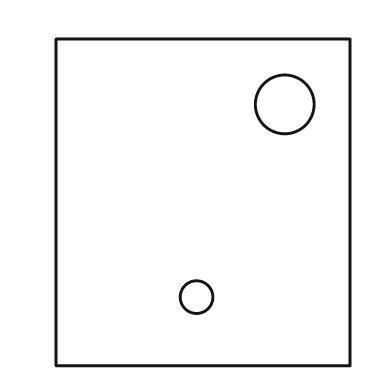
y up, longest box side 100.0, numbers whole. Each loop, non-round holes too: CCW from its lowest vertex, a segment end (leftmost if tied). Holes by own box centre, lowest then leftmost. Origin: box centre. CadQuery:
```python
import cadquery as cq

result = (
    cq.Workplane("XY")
    .moveTo(-45.0, -50.0)
    .lineTo(45.0, -50.0)
    .lineTo(45.0, 50.0)
    .lineTo(-45.0, 50.0)
    .close()
    .moveTo(-2.0, -29.0)
    .circle(5.0)
    .moveTo(25.0, 30.0)
    .circle(9.0)
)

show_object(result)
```